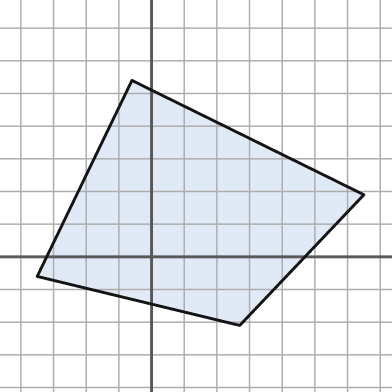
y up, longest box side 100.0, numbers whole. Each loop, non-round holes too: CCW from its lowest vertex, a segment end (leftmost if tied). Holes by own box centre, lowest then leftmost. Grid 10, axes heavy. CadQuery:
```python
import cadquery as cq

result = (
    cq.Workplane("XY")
    .moveTo(27.0, -21.0)
    .lineTo(65.0, 19.0)
    .lineTo(-6.0, 54.0)
    .lineTo(-35.0, -6.0)
    .close()
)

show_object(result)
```